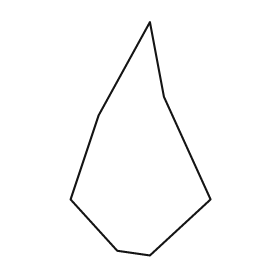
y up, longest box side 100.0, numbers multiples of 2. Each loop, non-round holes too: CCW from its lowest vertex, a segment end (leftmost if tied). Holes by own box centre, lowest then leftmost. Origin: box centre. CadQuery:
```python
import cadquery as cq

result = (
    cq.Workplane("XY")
    .moveTo(4.0, -50.0)
    .lineTo(30.0, -26.0)
    .lineTo(10.0, 18.0)
    .lineTo(4.0, 50.0)
    .lineTo(-18.0, 10.0)
    .lineTo(-30.0, -26.0)
    .lineTo(-10.0, -48.0)
    .close()
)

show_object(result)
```